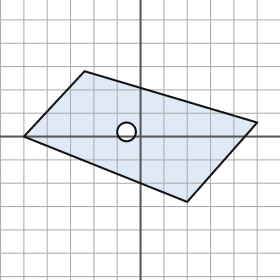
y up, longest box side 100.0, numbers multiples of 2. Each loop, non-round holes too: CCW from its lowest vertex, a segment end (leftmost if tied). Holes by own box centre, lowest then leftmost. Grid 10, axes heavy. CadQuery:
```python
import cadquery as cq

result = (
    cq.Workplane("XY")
    .moveTo(20.0, -28.0)
    .lineTo(50.0, 6.0)
    .lineTo(-24.0, 28.0)
    .lineTo(-50.0, 0.0)
    .close()
    .moveTo(-6.0, 2.0)
    .circle(4.0)
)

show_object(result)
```